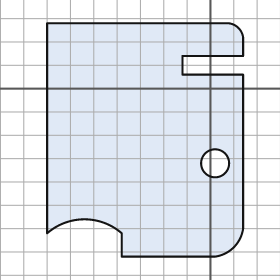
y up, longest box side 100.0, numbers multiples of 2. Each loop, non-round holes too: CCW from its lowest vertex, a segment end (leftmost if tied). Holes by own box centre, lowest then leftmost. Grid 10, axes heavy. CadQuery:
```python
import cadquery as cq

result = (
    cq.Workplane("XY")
    .moveTo(-38.0, -72.0)
    .lineTo(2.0, -72.0)
    .threePointArc((10.0, -68.0), (14.0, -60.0))
    .lineTo(14.0, 6.0)
    .lineTo(-12.0, 6.0)
    .lineTo(-12.0, 14.0)
    .lineTo(14.0, 14.0)
    .lineTo(14.0, 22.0)
    .threePointArc((12.0, 26.0), (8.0, 28.0))
    .lineTo(-70.0, 28.0)
    .lineTo(-70.0, -62.0)
    .threePointArc((-54.0, -56.0), (-38.0, -62.0))
    .close()
    .moveTo(2.0, -32.0)
    .circle(6.0)
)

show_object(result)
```